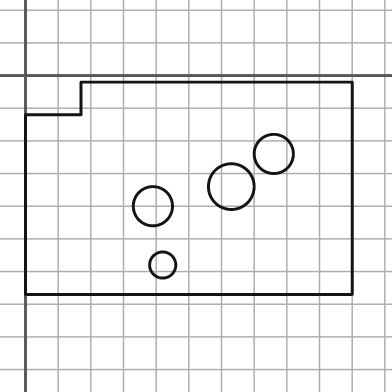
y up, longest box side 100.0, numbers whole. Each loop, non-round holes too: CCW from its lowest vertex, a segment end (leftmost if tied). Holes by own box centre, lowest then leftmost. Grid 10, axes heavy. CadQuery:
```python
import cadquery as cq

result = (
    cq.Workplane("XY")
    .moveTo(0.0, -67.0)
    .lineTo(100.0, -67.0)
    .lineTo(100.0, -2.0)
    .lineTo(17.0, -2.0)
    .lineTo(17.0, -12.0)
    .lineTo(0.0, -12.0)
    .close()
    .moveTo(42.0, -58.0)
    .circle(4.0)
    .moveTo(39.0, -40.0)
    .circle(6.0)
    .moveTo(63.0, -34.0)
    .circle(7.0)
    .moveTo(76.0, -24.0)
    .circle(6.0)
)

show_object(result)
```